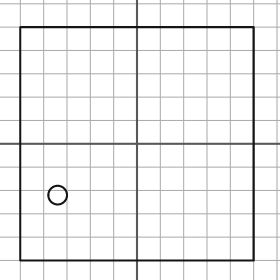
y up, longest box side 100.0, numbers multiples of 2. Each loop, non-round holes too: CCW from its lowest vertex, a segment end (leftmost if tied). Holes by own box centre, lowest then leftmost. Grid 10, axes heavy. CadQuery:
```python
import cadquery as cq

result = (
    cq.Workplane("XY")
    .moveTo(-50.0, -50.0)
    .lineTo(50.0, -50.0)
    .lineTo(50.0, 50.0)
    .lineTo(-50.0, 50.0)
    .close()
    .moveTo(-34.0, -22.0)
    .circle(4.0)
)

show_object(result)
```